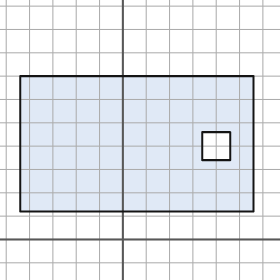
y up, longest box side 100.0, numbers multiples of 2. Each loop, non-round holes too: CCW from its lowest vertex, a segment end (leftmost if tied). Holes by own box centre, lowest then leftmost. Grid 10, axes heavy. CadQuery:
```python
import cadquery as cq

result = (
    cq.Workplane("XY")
    .moveTo(-44.0, 12.0)
    .lineTo(56.0, 12.0)
    .lineTo(56.0, 70.0)
    .lineTo(-44.0, 70.0)
    .close()
    .moveTo(34.0, 34.0)
    .lineTo(46.0, 34.0)
    .lineTo(46.0, 46.0)
    .lineTo(34.0, 46.0)
    .close()
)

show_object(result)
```